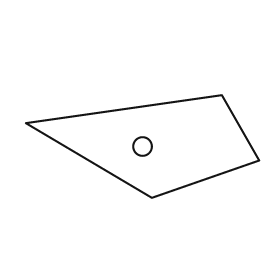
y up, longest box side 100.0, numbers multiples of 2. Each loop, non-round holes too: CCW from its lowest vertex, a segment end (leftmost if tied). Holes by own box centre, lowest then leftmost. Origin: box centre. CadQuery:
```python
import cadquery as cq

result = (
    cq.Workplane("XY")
    .moveTo(4.0, -22.0)
    .lineTo(50.0, -6.0)
    .lineTo(34.0, 22.0)
    .lineTo(-50.0, 10.0)
    .close()
    .moveTo(0.0, 0.0)
    .circle(4.0)
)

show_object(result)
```